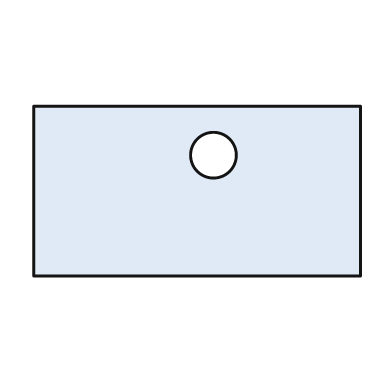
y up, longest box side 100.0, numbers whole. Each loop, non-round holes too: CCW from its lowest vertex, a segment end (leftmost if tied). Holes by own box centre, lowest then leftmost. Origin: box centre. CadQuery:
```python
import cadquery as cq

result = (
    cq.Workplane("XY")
    .moveTo(-50.0, -26.0)
    .lineTo(50.0, -26.0)
    .lineTo(50.0, 26.0)
    .lineTo(-50.0, 26.0)
    .close()
    .moveTo(5.0, 11.0)
    .circle(7.0)
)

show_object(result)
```